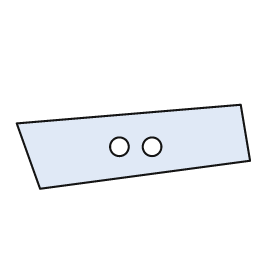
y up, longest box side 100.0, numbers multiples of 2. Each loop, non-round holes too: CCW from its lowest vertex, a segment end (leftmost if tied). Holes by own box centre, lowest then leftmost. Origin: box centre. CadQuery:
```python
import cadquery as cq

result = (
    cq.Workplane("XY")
    .moveTo(-40.0, -18.0)
    .lineTo(50.0, -6.0)
    .lineTo(46.0, 18.0)
    .lineTo(-50.0, 10.0)
    .close()
    .moveTo(-6.0, 0.0)
    .circle(4.0)
    .moveTo(8.0, 0.0)
    .circle(4.0)
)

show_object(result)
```